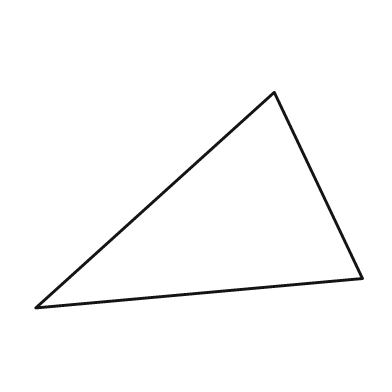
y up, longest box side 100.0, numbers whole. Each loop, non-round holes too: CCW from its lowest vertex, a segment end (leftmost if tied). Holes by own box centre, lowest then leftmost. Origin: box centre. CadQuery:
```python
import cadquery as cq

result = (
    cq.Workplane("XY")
    .moveTo(-50.0, -33.0)
    .lineTo(50.0, -24.0)
    .lineTo(23.0, 33.0)
    .close()
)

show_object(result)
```